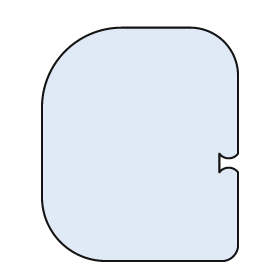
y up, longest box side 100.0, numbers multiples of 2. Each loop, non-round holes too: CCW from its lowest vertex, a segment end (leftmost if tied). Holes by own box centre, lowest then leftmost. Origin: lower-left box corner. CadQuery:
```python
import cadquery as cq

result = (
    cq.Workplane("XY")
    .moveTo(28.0, 0.0)
    .lineTo(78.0, 0.0)
    .threePointArc((82.0, 2.0), (84.0, 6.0))
    .lineTo(84.0, 38.0)
    .threePointArc((80.0, 40.0), (76.0, 38.0))
    .lineTo(76.0, 46.0)
    .threePointArc((80.0, 44.0), (84.0, 46.0))
    .lineTo(84.0, 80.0)
    .threePointArc((78.0, 94.0), (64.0, 100.0))
    .lineTo(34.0, 100.0)
    .threePointArc((10.0, 90.0), (0.0, 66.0))
    .lineTo(0.0, 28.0)
    .threePointArc((8.0, 8.0), (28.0, 0.0))
    .close()
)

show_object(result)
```